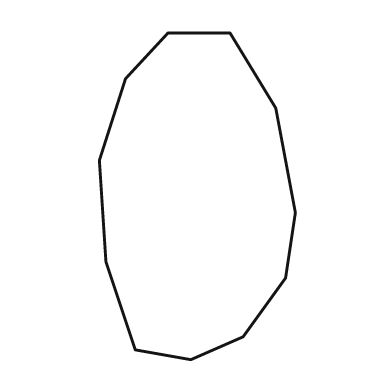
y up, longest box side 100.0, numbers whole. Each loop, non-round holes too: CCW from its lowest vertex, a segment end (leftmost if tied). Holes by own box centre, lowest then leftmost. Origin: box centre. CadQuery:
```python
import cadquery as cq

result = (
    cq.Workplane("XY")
    .moveTo(-2.0, -50.0)
    .lineTo(14.0, -43.0)
    .lineTo(27.0, -25.0)
    .lineTo(30.0, -5.0)
    .lineTo(24.0, 27.0)
    .lineTo(10.0, 50.0)
    .lineTo(-9.0, 50.0)
    .lineTo(-22.0, 36.0)
    .lineTo(-30.0, 11.0)
    .lineTo(-28.0, -20.0)
    .lineTo(-19.0, -47.0)
    .close()
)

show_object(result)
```